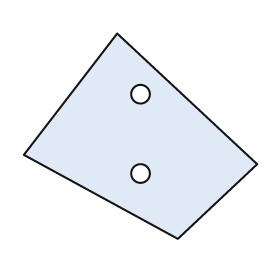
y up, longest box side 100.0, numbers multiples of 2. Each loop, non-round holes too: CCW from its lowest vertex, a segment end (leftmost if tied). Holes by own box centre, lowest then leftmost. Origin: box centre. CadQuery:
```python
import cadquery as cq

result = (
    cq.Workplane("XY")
    .moveTo(16.0, -44.0)
    .lineTo(50.0, -12.0)
    .lineTo(-10.0, 44.0)
    .lineTo(-50.0, -8.0)
    .close()
    .moveTo(0.0, -16.0)
    .circle(4.0)
    .moveTo(0.0, 18.0)
    .circle(4.0)
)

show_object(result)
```